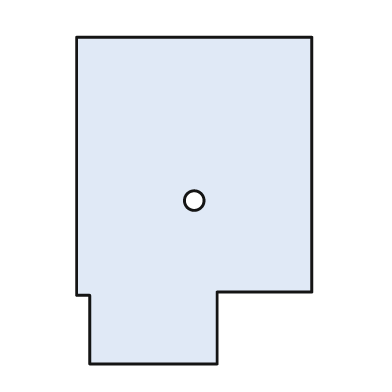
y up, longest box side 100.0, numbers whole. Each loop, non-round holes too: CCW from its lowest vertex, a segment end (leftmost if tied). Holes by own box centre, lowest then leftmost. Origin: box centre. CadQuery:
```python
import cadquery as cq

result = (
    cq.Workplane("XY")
    .moveTo(-32.0, -50.0)
    .lineTo(7.0, -50.0)
    .lineTo(7.0, -28.0)
    .lineTo(36.0, -28.0)
    .lineTo(36.0, 50.0)
    .lineTo(-36.0, 50.0)
    .lineTo(-36.0, -29.0)
    .lineTo(-32.0, -29.0)
    .close()
    .moveTo(0.0, 0.0)
    .circle(3.0)
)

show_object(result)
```